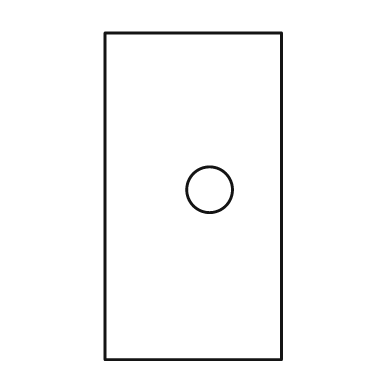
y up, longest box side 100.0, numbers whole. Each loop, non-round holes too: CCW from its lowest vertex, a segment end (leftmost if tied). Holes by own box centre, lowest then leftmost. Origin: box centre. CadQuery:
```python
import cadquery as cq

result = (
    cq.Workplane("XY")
    .moveTo(-27.0, -50.0)
    .lineTo(27.0, -50.0)
    .lineTo(27.0, 50.0)
    .lineTo(-27.0, 50.0)
    .close()
    .moveTo(5.0, 2.0)
    .circle(7.0)
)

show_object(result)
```